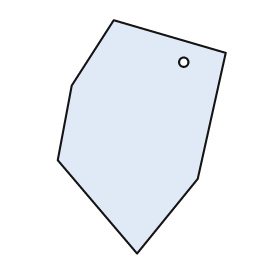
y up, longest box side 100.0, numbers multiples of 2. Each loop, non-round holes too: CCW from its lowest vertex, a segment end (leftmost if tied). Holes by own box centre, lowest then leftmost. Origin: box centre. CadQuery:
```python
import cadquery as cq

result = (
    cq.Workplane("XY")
    .moveTo(-2.0, -50.0)
    .lineTo(24.0, -18.0)
    .lineTo(36.0, 36.0)
    .lineTo(-12.0, 50.0)
    .lineTo(-30.0, 22.0)
    .lineTo(-36.0, -10.0)
    .close()
    .moveTo(18.0, 32.0)
    .circle(2.0)
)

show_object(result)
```